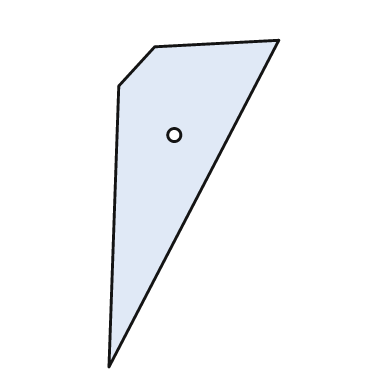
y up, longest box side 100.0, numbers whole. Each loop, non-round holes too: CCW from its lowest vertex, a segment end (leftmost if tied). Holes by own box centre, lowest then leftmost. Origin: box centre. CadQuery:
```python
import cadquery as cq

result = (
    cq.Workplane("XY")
    .moveTo(-26.0, -50.0)
    .lineTo(26.0, 50.0)
    .lineTo(-12.0, 48.0)
    .lineTo(-23.0, 36.0)
    .close()
    .moveTo(-6.0, 21.0)
    .circle(2.0)
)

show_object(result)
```